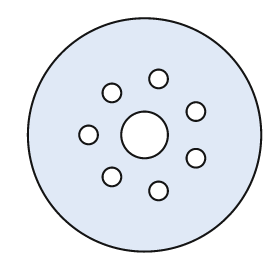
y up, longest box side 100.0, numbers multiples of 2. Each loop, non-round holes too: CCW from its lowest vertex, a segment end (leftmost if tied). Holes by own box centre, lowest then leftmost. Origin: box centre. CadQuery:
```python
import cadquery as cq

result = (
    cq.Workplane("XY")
    .moveTo(0.0, 0.0)
    .circle(50.0)
    .moveTo(6.0, -24.0)
    .circle(4.0)
    .moveTo(-14.0, -18.0)
    .circle(4.0)
    .moveTo(22.0, -10.0)
    .circle(4.0)
    .moveTo(-24.0, 0.0)
    .circle(4.0)
    .moveTo(0.0, 0.0)
    .circle(10.0)
    .moveTo(22.0, 10.0)
    .circle(4.0)
    .moveTo(-14.0, 18.0)
    .circle(4.0)
    .moveTo(6.0, 24.0)
    .circle(4.0)
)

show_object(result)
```